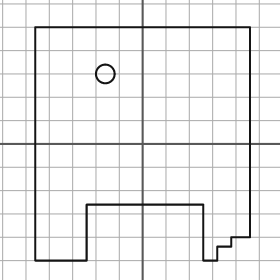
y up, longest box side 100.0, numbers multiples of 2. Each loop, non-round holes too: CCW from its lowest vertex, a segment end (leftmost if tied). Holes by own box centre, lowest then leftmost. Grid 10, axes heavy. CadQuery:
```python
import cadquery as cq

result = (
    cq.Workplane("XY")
    .moveTo(-46.0, -50.0)
    .lineTo(-24.0, -50.0)
    .lineTo(-24.0, -26.0)
    .lineTo(26.0, -26.0)
    .lineTo(26.0, -50.0)
    .lineTo(32.0, -50.0)
    .lineTo(32.0, -44.0)
    .lineTo(38.0, -44.0)
    .lineTo(38.0, -40.0)
    .lineTo(46.0, -40.0)
    .lineTo(46.0, 50.0)
    .lineTo(-46.0, 50.0)
    .close()
    .moveTo(-16.0, 30.0)
    .circle(4.0)
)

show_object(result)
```